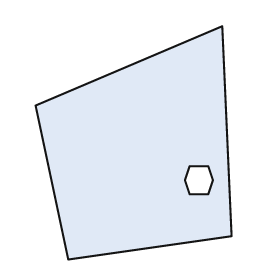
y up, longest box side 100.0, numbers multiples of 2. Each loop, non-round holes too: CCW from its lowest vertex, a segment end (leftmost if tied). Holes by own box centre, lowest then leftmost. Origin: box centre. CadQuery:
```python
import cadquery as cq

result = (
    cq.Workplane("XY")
    .moveTo(-28.0, -50.0)
    .lineTo(42.0, -40.0)
    .lineTo(38.0, 50.0)
    .lineTo(-42.0, 16.0)
    .close()
    .moveTo(24.0, -22.0)
    .lineTo(32.0, -22.0)
    .lineTo(34.0, -16.0)
    .lineTo(32.0, -10.0)
    .lineTo(24.0, -10.0)
    .lineTo(22.0, -16.0)
    .close()
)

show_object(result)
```